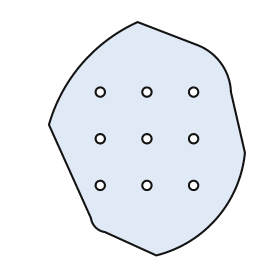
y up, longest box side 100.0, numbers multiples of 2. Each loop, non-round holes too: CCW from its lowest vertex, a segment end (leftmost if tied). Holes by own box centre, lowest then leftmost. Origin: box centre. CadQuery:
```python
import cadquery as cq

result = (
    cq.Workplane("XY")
    .moveTo(4.0, -50.0)
    .threePointArc((30.0, -34.0), (42.0, -6.0))
    .lineTo(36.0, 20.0)
    .threePointArc((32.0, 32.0), (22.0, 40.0))
    .lineTo(-4.0, 50.0)
    .threePointArc((-28.0, 32.0), (-42.0, 6.0))
    .lineTo(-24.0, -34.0)
    .threePointArc((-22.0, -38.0), (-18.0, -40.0))
    .close()
    .moveTo(-20.0, -20.0)
    .circle(2.0)
    .moveTo(0.0, -20.0)
    .circle(2.0)
    .moveTo(20.0, -20.0)
    .circle(2.0)
    .moveTo(-20.0, 0.0)
    .circle(2.0)
    .moveTo(0.0, 0.0)
    .circle(2.0)
    .moveTo(20.0, 0.0)
    .circle(2.0)
    .moveTo(-20.0, 20.0)
    .circle(2.0)
    .moveTo(0.0, 20.0)
    .circle(2.0)
    .moveTo(20.0, 20.0)
    .circle(2.0)
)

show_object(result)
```